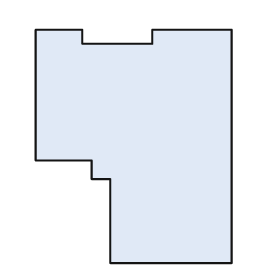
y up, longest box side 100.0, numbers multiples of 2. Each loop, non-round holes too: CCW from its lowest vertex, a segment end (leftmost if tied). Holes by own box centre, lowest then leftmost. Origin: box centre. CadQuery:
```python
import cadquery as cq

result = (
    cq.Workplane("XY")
    .moveTo(-10.0, -50.0)
    .lineTo(42.0, -50.0)
    .lineTo(42.0, 50.0)
    .lineTo(8.0, 50.0)
    .lineTo(8.0, 44.0)
    .lineTo(-22.0, 44.0)
    .lineTo(-22.0, 50.0)
    .lineTo(-42.0, 50.0)
    .lineTo(-42.0, -6.0)
    .lineTo(-18.0, -6.0)
    .lineTo(-18.0, -14.0)
    .lineTo(-10.0, -14.0)
    .close()
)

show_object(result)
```